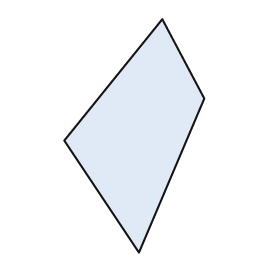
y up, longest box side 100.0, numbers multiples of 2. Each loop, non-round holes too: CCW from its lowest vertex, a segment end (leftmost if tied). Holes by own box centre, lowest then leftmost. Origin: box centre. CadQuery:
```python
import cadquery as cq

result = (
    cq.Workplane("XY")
    .moveTo(2.0, -50.0)
    .lineTo(30.0, 16.0)
    .lineTo(12.0, 50.0)
    .lineTo(-30.0, -2.0)
    .close()
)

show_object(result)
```